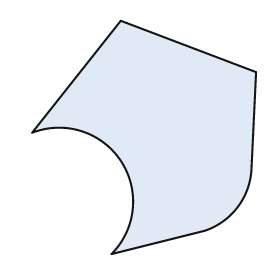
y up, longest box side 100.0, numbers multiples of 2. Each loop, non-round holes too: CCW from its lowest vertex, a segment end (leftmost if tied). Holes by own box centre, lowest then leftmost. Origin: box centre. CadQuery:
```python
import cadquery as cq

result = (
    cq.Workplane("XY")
    .moveTo(-14.0, -50.0)
    .lineTo(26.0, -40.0)
    .threePointArc((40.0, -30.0), (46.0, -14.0))
    .lineTo(48.0, 28.0)
    .lineTo(-10.0, 50.0)
    .lineTo(-48.0, 2.0)
    .threePointArc((-10.0, -10.0), (-14.0, -50.0))
    .close()
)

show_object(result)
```